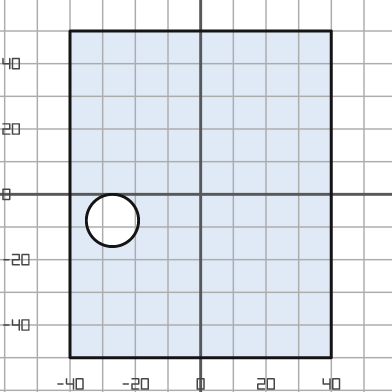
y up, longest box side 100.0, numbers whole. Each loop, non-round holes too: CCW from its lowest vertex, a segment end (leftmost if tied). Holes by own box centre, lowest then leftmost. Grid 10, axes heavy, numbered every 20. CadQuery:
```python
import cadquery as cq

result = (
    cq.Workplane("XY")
    .moveTo(-40.0, -50.0)
    .lineTo(40.0, -50.0)
    .lineTo(40.0, 50.0)
    .lineTo(-40.0, 50.0)
    .close()
    .moveTo(-27.0, -8.0)
    .circle(8.0)
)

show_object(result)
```